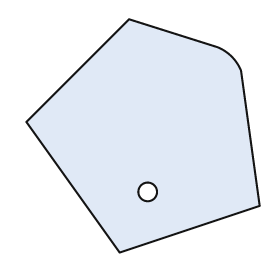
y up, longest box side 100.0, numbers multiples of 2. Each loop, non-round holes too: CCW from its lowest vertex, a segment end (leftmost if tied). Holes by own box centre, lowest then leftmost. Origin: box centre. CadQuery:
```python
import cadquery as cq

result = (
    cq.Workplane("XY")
    .moveTo(-10.0, -50.0)
    .lineTo(50.0, -30.0)
    .lineTo(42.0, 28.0)
    .threePointArc((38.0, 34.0), (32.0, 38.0))
    .lineTo(-6.0, 50.0)
    .lineTo(-50.0, 6.0)
    .close()
    .moveTo(2.0, -24.0)
    .circle(4.0)
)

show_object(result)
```